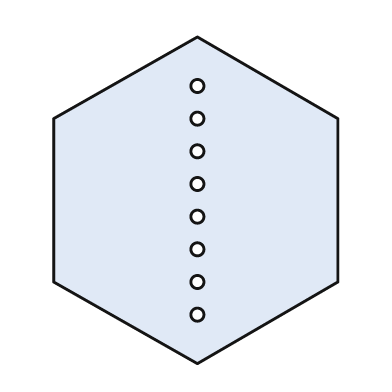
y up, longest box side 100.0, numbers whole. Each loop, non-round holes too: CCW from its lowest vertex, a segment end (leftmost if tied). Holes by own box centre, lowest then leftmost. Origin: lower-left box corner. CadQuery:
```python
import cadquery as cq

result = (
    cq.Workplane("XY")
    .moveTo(44.0, 0.0)
    .lineTo(87.0, 25.0)
    .lineTo(87.0, 75.0)
    .lineTo(44.0, 100.0)
    .lineTo(0.0, 75.0)
    .lineTo(0.0, 25.0)
    .close()
    .moveTo(44.0, 15.0)
    .circle(2.0)
    .moveTo(44.0, 25.0)
    .circle(2.0)
    .moveTo(44.0, 35.0)
    .circle(2.0)
    .moveTo(44.0, 45.0)
    .circle(2.0)
    .moveTo(44.0, 55.0)
    .circle(2.0)
    .moveTo(44.0, 65.0)
    .circle(2.0)
    .moveTo(44.0, 75.0)
    .circle(2.0)
    .moveTo(44.0, 85.0)
    .circle(2.0)
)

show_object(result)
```